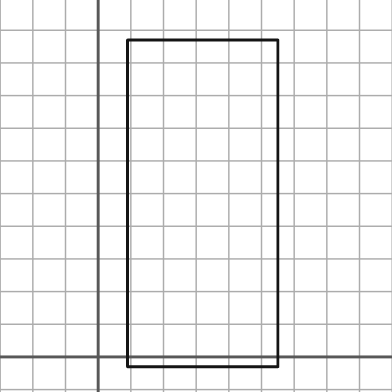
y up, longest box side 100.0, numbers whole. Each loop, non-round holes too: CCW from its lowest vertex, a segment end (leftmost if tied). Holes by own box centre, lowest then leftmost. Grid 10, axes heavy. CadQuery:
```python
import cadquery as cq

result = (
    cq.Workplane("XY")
    .moveTo(9.0, -3.0)
    .lineTo(55.0, -3.0)
    .lineTo(55.0, 97.0)
    .lineTo(9.0, 97.0)
    .close()
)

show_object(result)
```